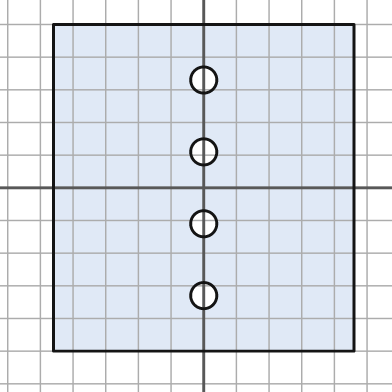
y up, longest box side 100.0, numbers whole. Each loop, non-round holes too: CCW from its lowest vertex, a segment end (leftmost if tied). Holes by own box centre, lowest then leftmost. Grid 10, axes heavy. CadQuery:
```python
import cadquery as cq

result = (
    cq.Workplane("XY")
    .moveTo(-46.0, -50.0)
    .lineTo(46.0, -50.0)
    .lineTo(46.0, 50.0)
    .lineTo(-46.0, 50.0)
    .close()
    .moveTo(0.0, -33.0)
    .circle(4.0)
    .moveTo(0.0, -11.0)
    .circle(4.0)
    .moveTo(0.0, 11.0)
    .circle(4.0)
    .moveTo(0.0, 33.0)
    .circle(4.0)
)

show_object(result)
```